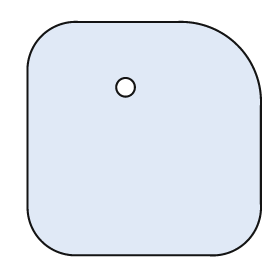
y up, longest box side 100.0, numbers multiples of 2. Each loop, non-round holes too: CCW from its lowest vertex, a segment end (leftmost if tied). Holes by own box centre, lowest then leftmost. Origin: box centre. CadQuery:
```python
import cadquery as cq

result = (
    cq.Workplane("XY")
    .moveTo(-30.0, -50.0)
    .lineTo(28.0, -50.0)
    .threePointArc((44.0, -44.0), (50.0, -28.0))
    .lineTo(50.0, 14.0)
    .threePointArc((40.0, 40.0), (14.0, 50.0))
    .lineTo(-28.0, 50.0)
    .threePointArc((-44.0, 44.0), (-50.0, 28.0))
    .lineTo(-50.0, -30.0)
    .threePointArc((-44.0, -44.0), (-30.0, -50.0))
    .close()
    .moveTo(-8.0, 22.0)
    .circle(4.0)
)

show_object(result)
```